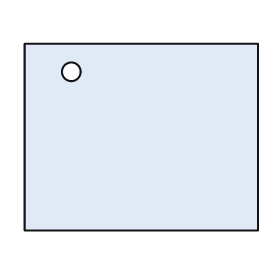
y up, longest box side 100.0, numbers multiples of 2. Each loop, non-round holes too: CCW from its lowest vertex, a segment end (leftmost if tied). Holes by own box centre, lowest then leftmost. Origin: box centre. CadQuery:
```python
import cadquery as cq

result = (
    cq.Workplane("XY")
    .moveTo(-50.0, -40.0)
    .lineTo(50.0, -40.0)
    .lineTo(50.0, 40.0)
    .lineTo(-50.0, 40.0)
    .close()
    .moveTo(-30.0, 28.0)
    .circle(4.0)
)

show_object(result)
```